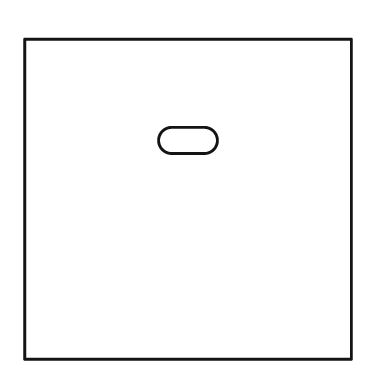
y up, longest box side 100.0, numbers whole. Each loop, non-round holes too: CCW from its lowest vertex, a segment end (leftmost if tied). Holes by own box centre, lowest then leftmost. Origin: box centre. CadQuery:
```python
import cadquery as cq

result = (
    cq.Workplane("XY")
    .moveTo(-50.0, -49.0)
    .lineTo(50.0, -49.0)
    .lineTo(50.0, 49.0)
    .lineTo(-50.0, 49.0)
    .close()
    .moveTo(-5.0, 14.0)
    .lineTo(5.0, 14.0)
    .threePointArc((9.0, 18.0), (5.0, 22.0))
    .lineTo(-5.0, 22.0)
    .threePointArc((-9.0, 18.0), (-5.0, 14.0))
    .close()
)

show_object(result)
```